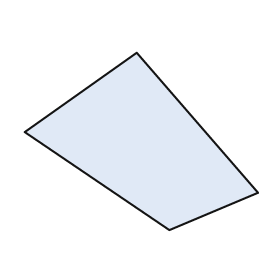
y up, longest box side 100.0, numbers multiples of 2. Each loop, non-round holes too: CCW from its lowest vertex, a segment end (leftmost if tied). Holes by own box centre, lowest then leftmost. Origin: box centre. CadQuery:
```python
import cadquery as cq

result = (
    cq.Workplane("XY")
    .moveTo(12.0, -38.0)
    .lineTo(50.0, -22.0)
    .lineTo(-2.0, 38.0)
    .lineTo(-50.0, 4.0)
    .close()
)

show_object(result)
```